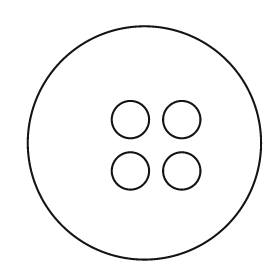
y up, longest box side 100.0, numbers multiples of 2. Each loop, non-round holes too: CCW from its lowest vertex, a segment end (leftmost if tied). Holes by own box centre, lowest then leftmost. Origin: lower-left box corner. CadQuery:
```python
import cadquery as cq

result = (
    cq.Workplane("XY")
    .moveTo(50.0, 50.0)
    .circle(50.0)
    .moveTo(44.0, 38.0)
    .circle(8.0)
    .moveTo(66.0, 38.0)
    .circle(8.0)
    .moveTo(44.0, 60.0)
    .circle(8.0)
    .moveTo(66.0, 60.0)
    .circle(8.0)
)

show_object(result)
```